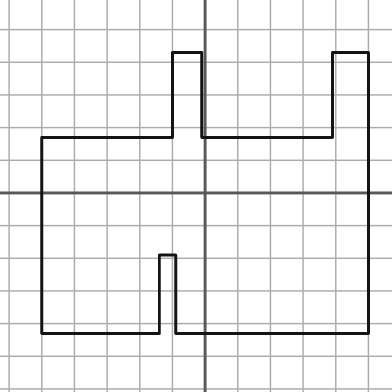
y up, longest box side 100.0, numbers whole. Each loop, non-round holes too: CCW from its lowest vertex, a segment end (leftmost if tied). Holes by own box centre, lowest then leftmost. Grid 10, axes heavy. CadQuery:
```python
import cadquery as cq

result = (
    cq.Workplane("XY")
    .moveTo(-50.0, -43.0)
    .lineTo(-14.0, -43.0)
    .lineTo(-14.0, -19.0)
    .lineTo(-9.0, -19.0)
    .lineTo(-9.0, -43.0)
    .lineTo(50.0, -43.0)
    .lineTo(50.0, 43.0)
    .lineTo(39.0, 43.0)
    .lineTo(39.0, 17.0)
    .lineTo(-1.0, 17.0)
    .lineTo(-1.0, 43.0)
    .lineTo(-10.0, 43.0)
    .lineTo(-10.0, 17.0)
    .lineTo(-50.0, 17.0)
    .close()
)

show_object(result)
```